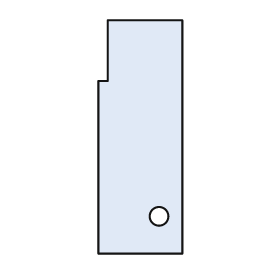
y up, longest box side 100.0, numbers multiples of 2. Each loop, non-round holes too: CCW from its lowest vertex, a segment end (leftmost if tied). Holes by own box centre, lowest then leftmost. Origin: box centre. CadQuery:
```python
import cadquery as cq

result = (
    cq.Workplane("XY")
    .moveTo(-18.0, -50.0)
    .lineTo(18.0, -50.0)
    .lineTo(18.0, 50.0)
    .lineTo(-14.0, 50.0)
    .lineTo(-14.0, 24.0)
    .lineTo(-18.0, 24.0)
    .close()
    .moveTo(8.0, -34.0)
    .circle(4.0)
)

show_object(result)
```